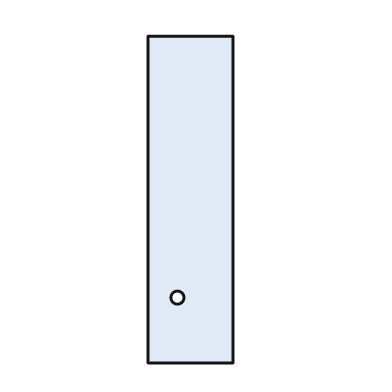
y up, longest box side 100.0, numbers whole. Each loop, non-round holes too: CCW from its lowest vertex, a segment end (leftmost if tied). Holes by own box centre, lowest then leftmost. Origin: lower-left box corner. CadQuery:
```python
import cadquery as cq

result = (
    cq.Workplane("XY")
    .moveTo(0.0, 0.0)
    .lineTo(26.0, 0.0)
    .lineTo(26.0, 100.0)
    .lineTo(0.0, 100.0)
    .close()
    .moveTo(9.0, 20.0)
    .circle(2.0)
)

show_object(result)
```